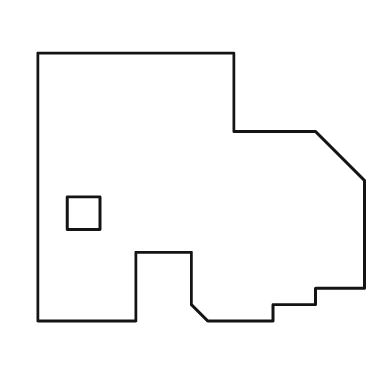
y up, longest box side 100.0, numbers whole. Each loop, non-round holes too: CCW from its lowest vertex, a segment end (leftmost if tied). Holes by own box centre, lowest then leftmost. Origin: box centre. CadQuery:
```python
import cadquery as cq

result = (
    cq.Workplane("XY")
    .moveTo(-50.0, -41.0)
    .lineTo(-20.0, -41.0)
    .lineTo(-20.0, -20.0)
    .lineTo(-3.0, -20.0)
    .lineTo(-3.0, -36.0)
    .lineTo(2.0, -41.0)
    .lineTo(22.0, -41.0)
    .lineTo(22.0, -36.0)
    .lineTo(35.0, -36.0)
    .lineTo(35.0, -31.0)
    .lineTo(50.0, -31.0)
    .lineTo(50.0, 2.0)
    .lineTo(35.0, 17.0)
    .lineTo(10.0, 17.0)
    .lineTo(10.0, 41.0)
    .lineTo(-50.0, 41.0)
    .close()
    .moveTo(-41.0, -13.0)
    .lineTo(-31.0, -13.0)
    .lineTo(-31.0, -3.0)
    .lineTo(-41.0, -3.0)
    .close()
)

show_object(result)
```